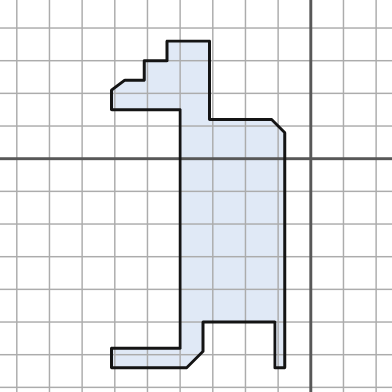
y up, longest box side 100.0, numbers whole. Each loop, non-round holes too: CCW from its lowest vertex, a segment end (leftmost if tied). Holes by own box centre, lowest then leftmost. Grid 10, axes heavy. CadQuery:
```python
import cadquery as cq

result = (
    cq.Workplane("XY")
    .moveTo(-61.0, -64.0)
    .lineTo(-38.0, -64.0)
    .lineTo(-33.0, -59.0)
    .lineTo(-33.0, -50.0)
    .lineTo(-11.0, -50.0)
    .lineTo(-11.0, -64.0)
    .lineTo(-8.0, -64.0)
    .lineTo(-8.0, 8.0)
    .lineTo(-12.0, 12.0)
    .lineTo(-31.0, 12.0)
    .lineTo(-31.0, 36.0)
    .lineTo(-44.0, 36.0)
    .lineTo(-44.0, 30.0)
    .lineTo(-51.0, 30.0)
    .lineTo(-51.0, 24.0)
    .lineTo(-57.0, 24.0)
    .lineTo(-61.0, 21.0)
    .lineTo(-61.0, 15.0)
    .lineTo(-40.0, 15.0)
    .lineTo(-40.0, -58.0)
    .lineTo(-61.0, -58.0)
    .close()
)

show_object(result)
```